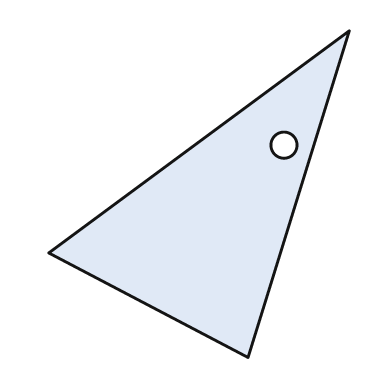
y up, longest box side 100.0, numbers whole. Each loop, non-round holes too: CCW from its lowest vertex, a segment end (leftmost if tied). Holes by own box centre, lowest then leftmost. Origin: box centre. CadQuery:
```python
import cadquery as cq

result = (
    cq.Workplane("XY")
    .moveTo(15.0, -50.0)
    .lineTo(46.0, 50.0)
    .lineTo(-46.0, -18.0)
    .close()
    .moveTo(26.0, 15.0)
    .circle(4.0)
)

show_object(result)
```